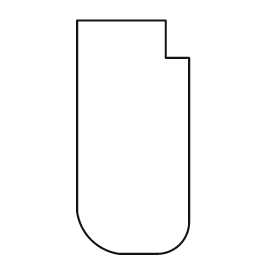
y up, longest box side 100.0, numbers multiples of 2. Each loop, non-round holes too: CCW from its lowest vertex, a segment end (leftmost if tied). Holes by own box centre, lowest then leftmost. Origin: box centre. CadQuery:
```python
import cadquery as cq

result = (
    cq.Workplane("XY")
    .moveTo(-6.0, -50.0)
    .lineTo(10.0, -50.0)
    .threePointArc((20.0, -46.0), (24.0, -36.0))
    .lineTo(24.0, 34.0)
    .lineTo(14.0, 34.0)
    .lineTo(14.0, 50.0)
    .lineTo(-24.0, 50.0)
    .lineTo(-24.0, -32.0)
    .threePointArc((-18.0, -44.0), (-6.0, -50.0))
    .close()
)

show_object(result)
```